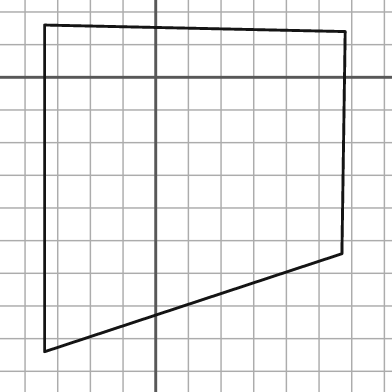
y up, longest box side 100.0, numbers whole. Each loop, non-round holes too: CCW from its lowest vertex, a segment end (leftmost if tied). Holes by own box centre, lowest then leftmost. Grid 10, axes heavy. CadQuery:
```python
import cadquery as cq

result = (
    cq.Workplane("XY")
    .moveTo(-34.0, -84.0)
    .lineTo(57.0, -54.0)
    .lineTo(58.0, 14.0)
    .lineTo(-34.0, 16.0)
    .close()
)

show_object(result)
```